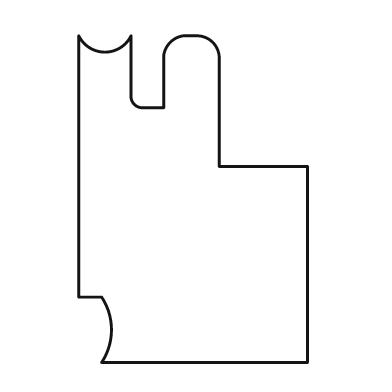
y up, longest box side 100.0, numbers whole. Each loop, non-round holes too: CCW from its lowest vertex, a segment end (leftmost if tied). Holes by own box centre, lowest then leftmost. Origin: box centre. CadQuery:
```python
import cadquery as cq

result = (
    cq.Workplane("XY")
    .moveTo(-28.0, -50.0)
    .lineTo(35.0, -50.0)
    .lineTo(35.0, 10.0)
    .lineTo(8.0, 10.0)
    .lineTo(8.0, 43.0)
    .threePointArc((6.0, 48.0), (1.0, 50.0))
    .lineTo(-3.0, 50.0)
    .threePointArc((-7.0, 48.0), (-9.0, 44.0))
    .lineTo(-9.0, 28.0)
    .lineTo(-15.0, 28.0)
    .threePointArc((-18.0, 29.0), (-19.0, 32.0))
    .lineTo(-19.0, 50.0)
    .threePointArc((-27.0, 45.0), (-35.0, 50.0))
    .lineTo(-35.0, -30.0)
    .lineTo(-28.0, -30.0)
    .threePointArc((-25.0, -40.0), (-28.0, -50.0))
    .close()
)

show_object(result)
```